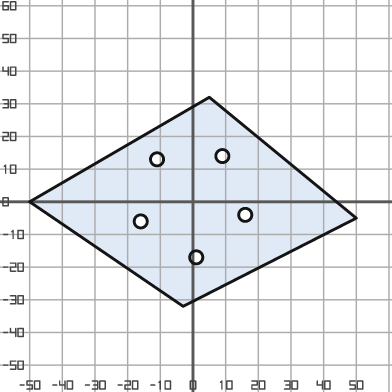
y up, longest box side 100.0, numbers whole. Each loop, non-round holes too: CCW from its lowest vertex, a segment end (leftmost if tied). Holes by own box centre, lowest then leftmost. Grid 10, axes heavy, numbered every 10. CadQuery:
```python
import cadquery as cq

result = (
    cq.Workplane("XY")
    .moveTo(-3.0, -32.0)
    .lineTo(50.0, -5.0)
    .lineTo(5.0, 32.0)
    .lineTo(-50.0, 0.0)
    .close()
    .moveTo(1.0, -17.0)
    .circle(2.0)
    .moveTo(-16.0, -6.0)
    .circle(2.0)
    .moveTo(16.0, -4.0)
    .circle(2.0)
    .moveTo(-11.0, 13.0)
    .circle(2.0)
    .moveTo(9.0, 14.0)
    .circle(2.0)
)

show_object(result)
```